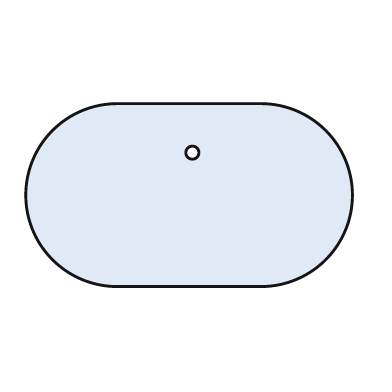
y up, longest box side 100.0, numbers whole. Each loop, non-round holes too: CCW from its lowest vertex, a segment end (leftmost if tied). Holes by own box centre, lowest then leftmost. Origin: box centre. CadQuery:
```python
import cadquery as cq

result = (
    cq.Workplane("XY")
    .moveTo(-22.0, -28.0)
    .lineTo(22.0, -28.0)
    .threePointArc((50.0, 0.0), (22.0, 28.0))
    .lineTo(-22.0, 28.0)
    .threePointArc((-50.0, 0.0), (-22.0, -28.0))
    .close()
    .moveTo(1.0, 13.0)
    .circle(2.0)
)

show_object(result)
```